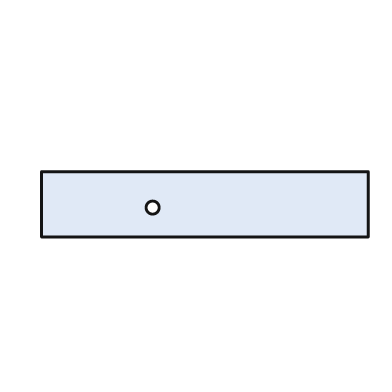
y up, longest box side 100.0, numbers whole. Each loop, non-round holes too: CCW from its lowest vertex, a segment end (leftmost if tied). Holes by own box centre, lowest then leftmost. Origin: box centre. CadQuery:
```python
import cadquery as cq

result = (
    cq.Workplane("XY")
    .moveTo(-50.0, -10.0)
    .lineTo(50.0, -10.0)
    .lineTo(50.0, 10.0)
    .lineTo(-50.0, 10.0)
    .close()
    .moveTo(-16.0, -1.0)
    .circle(2.0)
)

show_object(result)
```